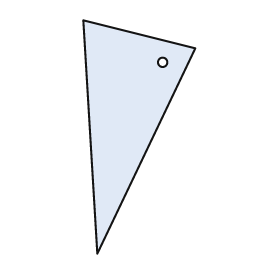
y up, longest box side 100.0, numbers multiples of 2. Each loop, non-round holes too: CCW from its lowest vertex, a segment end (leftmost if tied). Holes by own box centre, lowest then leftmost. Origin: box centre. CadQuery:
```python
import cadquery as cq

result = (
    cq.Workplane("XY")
    .moveTo(-18.0, -50.0)
    .lineTo(24.0, 38.0)
    .lineTo(-24.0, 50.0)
    .close()
    .moveTo(10.0, 32.0)
    .circle(2.0)
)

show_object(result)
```